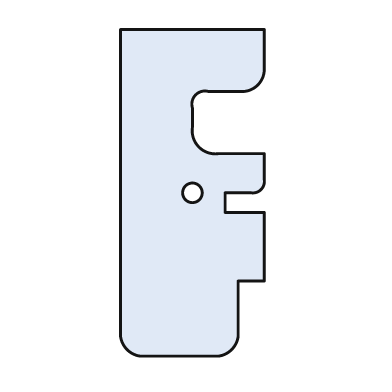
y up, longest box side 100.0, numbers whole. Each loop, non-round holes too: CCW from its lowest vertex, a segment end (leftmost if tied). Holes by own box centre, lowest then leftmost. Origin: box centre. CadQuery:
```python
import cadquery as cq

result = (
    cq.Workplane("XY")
    .moveTo(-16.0, -50.0)
    .lineTo(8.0, -50.0)
    .threePointArc((12.0, -48.0), (14.0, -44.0))
    .lineTo(14.0, -27.0)
    .lineTo(22.0, -27.0)
    .lineTo(22.0, -6.0)
    .lineTo(10.0, -6.0)
    .lineTo(10.0, 0.0)
    .lineTo(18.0, 0.0)
    .threePointArc((21.0, 1.0), (22.0, 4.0))
    .lineTo(22.0, 12.0)
    .lineTo(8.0, 12.0)
    .threePointArc((2.0, 14.0), (0.0, 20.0))
    .lineTo(0.0, 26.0)
    .threePointArc((1.0, 30.0), (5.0, 31.0))
    .lineTo(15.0, 31.0)
    .threePointArc((20.0, 33.0), (22.0, 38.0))
    .lineTo(22.0, 50.0)
    .lineTo(-22.0, 50.0)
    .lineTo(-22.0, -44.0)
    .threePointArc((-20.0, -48.0), (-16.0, -50.0))
    .close()
    .moveTo(0.0, 0.0)
    .circle(3.0)
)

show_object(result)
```